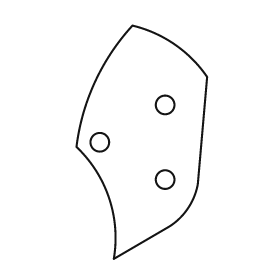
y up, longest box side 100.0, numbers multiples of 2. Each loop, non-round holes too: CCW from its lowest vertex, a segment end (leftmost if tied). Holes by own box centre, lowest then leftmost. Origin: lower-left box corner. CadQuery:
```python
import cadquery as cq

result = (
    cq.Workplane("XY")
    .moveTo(16.0, 0.0)
    .lineTo(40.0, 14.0)
    .threePointArc((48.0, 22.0), (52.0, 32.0))
    .lineTo(56.0, 78.0)
    .threePointArc((42.0, 92.0), (24.0, 100.0))
    .threePointArc((8.0, 76.0), (0.0, 48.0))
    .threePointArc((14.0, 26.0), (16.0, 0.0))
    .close()
    .moveTo(38.0, 34.0)
    .circle(4.0)
    .moveTo(10.0, 50.0)
    .circle(4.0)
    .moveTo(38.0, 66.0)
    .circle(4.0)
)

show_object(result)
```